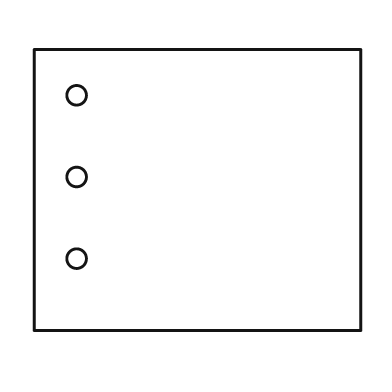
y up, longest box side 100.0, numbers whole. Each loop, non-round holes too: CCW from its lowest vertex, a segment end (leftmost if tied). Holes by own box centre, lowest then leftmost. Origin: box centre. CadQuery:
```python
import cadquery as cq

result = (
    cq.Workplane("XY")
    .moveTo(-50.0, -43.0)
    .lineTo(50.0, -43.0)
    .lineTo(50.0, 43.0)
    .lineTo(-50.0, 43.0)
    .close()
    .moveTo(-37.0, -21.0)
    .circle(3.0)
    .moveTo(-37.0, 4.0)
    .circle(3.0)
    .moveTo(-37.0, 29.0)
    .circle(3.0)
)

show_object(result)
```